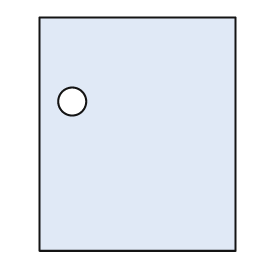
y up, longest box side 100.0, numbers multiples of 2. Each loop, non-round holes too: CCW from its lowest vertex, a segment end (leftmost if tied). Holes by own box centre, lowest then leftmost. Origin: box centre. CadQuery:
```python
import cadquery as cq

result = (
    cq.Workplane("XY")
    .moveTo(-42.0, -50.0)
    .lineTo(42.0, -50.0)
    .lineTo(42.0, 50.0)
    .lineTo(-42.0, 50.0)
    .close()
    .moveTo(-28.0, 14.0)
    .circle(6.0)
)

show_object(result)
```